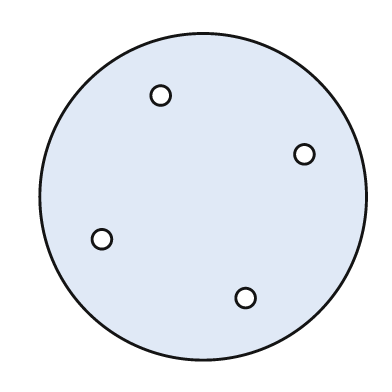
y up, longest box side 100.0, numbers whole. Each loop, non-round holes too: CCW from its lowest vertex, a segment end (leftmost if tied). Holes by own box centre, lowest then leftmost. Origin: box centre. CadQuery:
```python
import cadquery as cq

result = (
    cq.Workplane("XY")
    .moveTo(0.0, 0.0)
    .circle(50.0)
    .moveTo(13.0, -31.0)
    .circle(3.0)
    .moveTo(-31.0, -13.0)
    .circle(3.0)
    .moveTo(31.0, 13.0)
    .circle(3.0)
    .moveTo(-13.0, 31.0)
    .circle(3.0)
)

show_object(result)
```